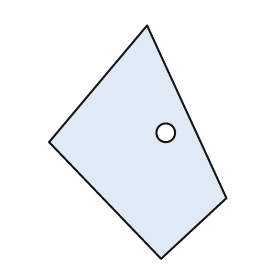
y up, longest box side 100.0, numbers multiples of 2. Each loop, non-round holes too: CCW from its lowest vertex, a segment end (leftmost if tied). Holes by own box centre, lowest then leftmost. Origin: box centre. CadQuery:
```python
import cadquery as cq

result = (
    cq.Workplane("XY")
    .moveTo(10.0, -50.0)
    .lineTo(38.0, -24.0)
    .lineTo(4.0, 50.0)
    .lineTo(-38.0, 0.0)
    .close()
    .moveTo(12.0, 4.0)
    .circle(4.0)
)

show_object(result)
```